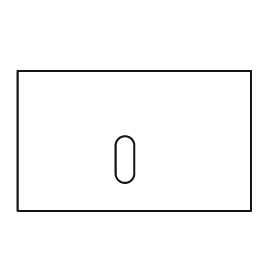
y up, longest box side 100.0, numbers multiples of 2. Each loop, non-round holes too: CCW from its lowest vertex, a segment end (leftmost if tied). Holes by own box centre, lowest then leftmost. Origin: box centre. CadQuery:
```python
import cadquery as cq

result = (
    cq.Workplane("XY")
    .moveTo(-50.0, -30.0)
    .lineTo(50.0, -30.0)
    .lineTo(50.0, 30.0)
    .lineTo(-50.0, 30.0)
    .close()
    .moveTo(-8.0, -14.0)
    .threePointArc((-4.0, -18.0), (0.0, -14.0))
    .lineTo(0.0, -2.0)
    .threePointArc((-4.0, 2.0), (-8.0, -2.0))
    .close()
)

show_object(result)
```